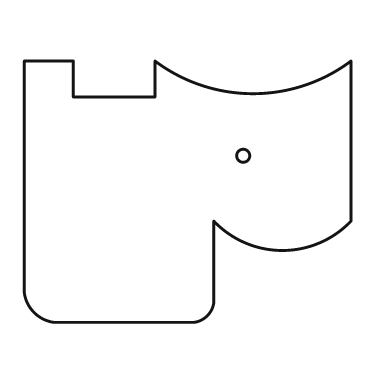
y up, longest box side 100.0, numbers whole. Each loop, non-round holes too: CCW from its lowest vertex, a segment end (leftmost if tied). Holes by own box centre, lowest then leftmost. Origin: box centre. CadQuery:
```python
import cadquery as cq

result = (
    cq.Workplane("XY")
    .moveTo(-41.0, -40.0)
    .lineTo(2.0, -40.0)
    .threePointArc((6.0, -38.0), (8.0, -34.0))
    .lineTo(8.0, -9.0)
    .threePointArc((29.0, -18.0), (50.0, -9.0))
    .lineTo(50.0, 40.0)
    .threePointArc((20.0, 30.0), (-10.0, 40.0))
    .lineTo(-10.0, 29.0)
    .lineTo(-35.0, 29.0)
    .lineTo(-35.0, 40.0)
    .lineTo(-50.0, 40.0)
    .lineTo(-50.0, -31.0)
    .threePointArc((-47.0, -37.0), (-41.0, -40.0))
    .close()
    .moveTo(17.0, 11.0)
    .circle(2.0)
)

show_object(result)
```